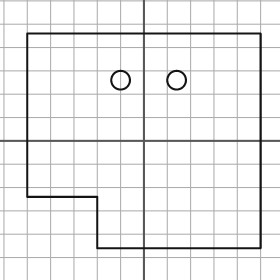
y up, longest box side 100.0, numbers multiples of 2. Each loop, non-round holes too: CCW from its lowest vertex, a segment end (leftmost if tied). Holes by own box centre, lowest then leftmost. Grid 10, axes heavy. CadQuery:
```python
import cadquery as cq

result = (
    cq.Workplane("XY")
    .moveTo(-20.0, -46.0)
    .lineTo(50.0, -46.0)
    .lineTo(50.0, 46.0)
    .lineTo(-50.0, 46.0)
    .lineTo(-50.0, -24.0)
    .lineTo(-20.0, -24.0)
    .close()
    .moveTo(-10.0, 26.0)
    .circle(4.0)
    .moveTo(14.0, 26.0)
    .circle(4.0)
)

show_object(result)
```